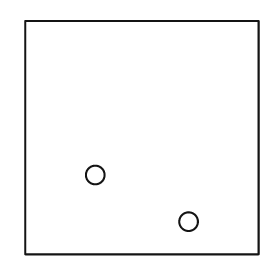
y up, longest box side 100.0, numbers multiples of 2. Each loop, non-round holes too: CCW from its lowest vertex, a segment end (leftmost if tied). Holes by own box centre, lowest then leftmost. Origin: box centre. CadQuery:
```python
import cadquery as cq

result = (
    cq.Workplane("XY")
    .moveTo(-50.0, -50.0)
    .lineTo(50.0, -50.0)
    .lineTo(50.0, 50.0)
    .lineTo(-50.0, 50.0)
    .close()
    .moveTo(20.0, -36.0)
    .circle(4.0)
    .moveTo(-20.0, -16.0)
    .circle(4.0)
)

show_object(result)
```